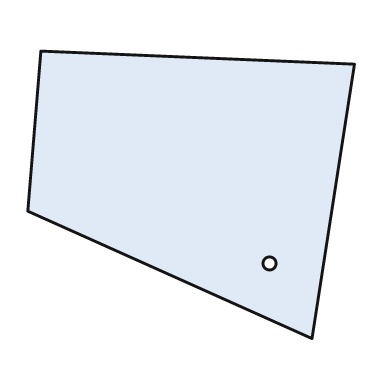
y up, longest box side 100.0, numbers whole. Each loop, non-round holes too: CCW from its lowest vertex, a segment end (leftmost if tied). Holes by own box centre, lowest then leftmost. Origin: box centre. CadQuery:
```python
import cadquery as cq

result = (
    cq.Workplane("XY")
    .moveTo(37.0, -44.0)
    .lineTo(50.0, 40.0)
    .lineTo(-46.0, 44.0)
    .lineTo(-50.0, -5.0)
    .close()
    .moveTo(24.0, -21.0)
    .circle(2.0)
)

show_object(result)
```